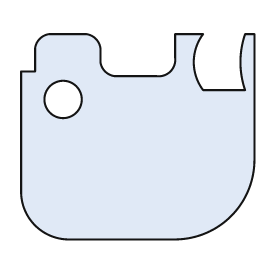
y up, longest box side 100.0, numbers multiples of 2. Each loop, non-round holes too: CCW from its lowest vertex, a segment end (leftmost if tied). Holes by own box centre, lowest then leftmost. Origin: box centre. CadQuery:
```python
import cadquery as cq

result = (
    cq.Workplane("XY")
    .moveTo(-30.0, -44.0)
    .lineTo(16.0, -44.0)
    .threePointArc((40.0, -34.0), (50.0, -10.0))
    .lineTo(50.0, 44.0)
    .lineTo(46.0, 44.0)
    .threePointArc((44.0, 32.0), (46.0, 20.0))
    .lineTo(28.0, 20.0)
    .threePointArc((24.0, 32.0), (28.0, 44.0))
    .lineTo(16.0, 44.0)
    .lineTo(16.0, 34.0)
    .threePointArc((14.0, 28.0), (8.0, 26.0))
    .lineTo(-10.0, 26.0)
    .threePointArc((-14.0, 28.0), (-16.0, 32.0))
    .lineTo(-16.0, 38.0)
    .threePointArc((-18.0, 42.0), (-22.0, 44.0))
    .lineTo(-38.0, 44.0)
    .threePointArc((-42.0, 42.0), (-44.0, 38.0))
    .lineTo(-44.0, 28.0)
    .lineTo(-50.0, 28.0)
    .lineTo(-50.0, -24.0)
    .threePointArc((-44.0, -38.0), (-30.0, -44.0))
    .close()
    .moveTo(-32.0, 16.0)
    .circle(8.0)
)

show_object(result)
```